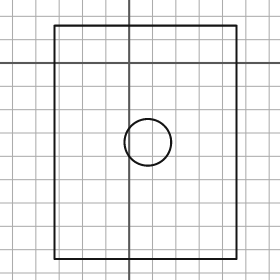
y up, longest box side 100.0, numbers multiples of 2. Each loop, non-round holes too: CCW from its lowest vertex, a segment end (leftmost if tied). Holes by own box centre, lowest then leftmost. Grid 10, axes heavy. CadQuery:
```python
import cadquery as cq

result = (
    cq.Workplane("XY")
    .moveTo(-32.0, -84.0)
    .lineTo(46.0, -84.0)
    .lineTo(46.0, 16.0)
    .lineTo(-32.0, 16.0)
    .close()
    .moveTo(8.0, -34.0)
    .circle(10.0)
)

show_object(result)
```